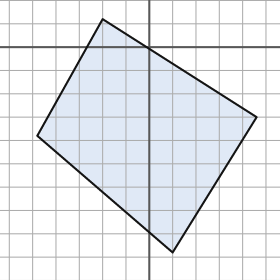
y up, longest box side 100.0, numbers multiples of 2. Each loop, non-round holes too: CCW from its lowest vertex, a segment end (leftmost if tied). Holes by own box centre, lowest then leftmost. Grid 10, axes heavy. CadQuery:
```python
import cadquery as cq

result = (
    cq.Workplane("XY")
    .moveTo(10.0, -88.0)
    .lineTo(46.0, -30.0)
    .lineTo(-20.0, 12.0)
    .lineTo(-48.0, -38.0)
    .close()
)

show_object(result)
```